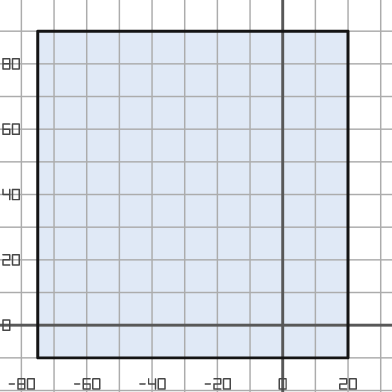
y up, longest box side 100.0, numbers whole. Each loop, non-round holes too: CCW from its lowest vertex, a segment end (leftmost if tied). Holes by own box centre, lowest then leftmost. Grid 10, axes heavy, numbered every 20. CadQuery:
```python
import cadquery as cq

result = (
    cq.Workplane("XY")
    .moveTo(-75.0, -10.0)
    .lineTo(20.0, -10.0)
    .lineTo(20.0, 90.0)
    .lineTo(-75.0, 90.0)
    .close()
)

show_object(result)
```